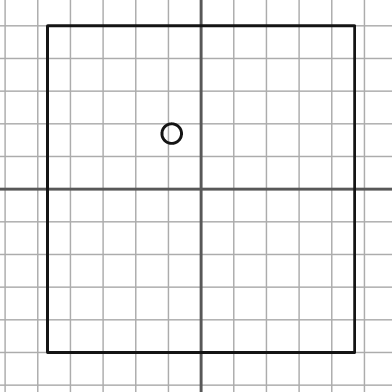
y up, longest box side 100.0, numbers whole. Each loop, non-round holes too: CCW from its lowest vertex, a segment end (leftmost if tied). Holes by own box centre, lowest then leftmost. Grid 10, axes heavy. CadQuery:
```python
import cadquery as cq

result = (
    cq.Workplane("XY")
    .moveTo(-47.0, -50.0)
    .lineTo(47.0, -50.0)
    .lineTo(47.0, 50.0)
    .lineTo(-47.0, 50.0)
    .close()
    .moveTo(-9.0, 17.0)
    .circle(3.0)
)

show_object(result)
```